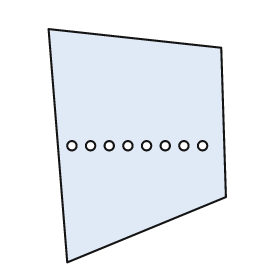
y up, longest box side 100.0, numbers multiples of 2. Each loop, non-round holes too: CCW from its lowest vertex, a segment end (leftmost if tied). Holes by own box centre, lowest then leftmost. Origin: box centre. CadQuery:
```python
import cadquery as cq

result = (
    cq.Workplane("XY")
    .moveTo(-30.0, -50.0)
    .lineTo(38.0, -22.0)
    .lineTo(36.0, 42.0)
    .lineTo(-38.0, 50.0)
    .close()
    .moveTo(-28.0, 0.0)
    .circle(2.0)
    .moveTo(-20.0, 0.0)
    .circle(2.0)
    .moveTo(-12.0, 0.0)
    .circle(2.0)
    .moveTo(-4.0, 0.0)
    .circle(2.0)
    .moveTo(4.0, 0.0)
    .circle(2.0)
    .moveTo(12.0, 0.0)
    .circle(2.0)
    .moveTo(20.0, 0.0)
    .circle(2.0)
    .moveTo(28.0, 0.0)
    .circle(2.0)
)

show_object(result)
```